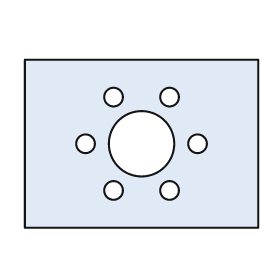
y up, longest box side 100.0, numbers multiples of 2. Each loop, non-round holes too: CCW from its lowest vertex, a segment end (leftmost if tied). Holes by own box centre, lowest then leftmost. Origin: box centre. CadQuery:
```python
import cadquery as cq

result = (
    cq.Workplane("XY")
    .moveTo(-50.0, -36.0)
    .lineTo(50.0, -36.0)
    .lineTo(50.0, 36.0)
    .lineTo(-50.0, 36.0)
    .close()
    .moveTo(-12.0, -20.0)
    .circle(4.0)
    .moveTo(12.0, -20.0)
    .circle(4.0)
    .moveTo(-24.0, 0.0)
    .circle(4.0)
    .moveTo(0.0, 0.0)
    .circle(14.0)
    .moveTo(24.0, 0.0)
    .circle(4.0)
    .moveTo(-12.0, 20.0)
    .circle(4.0)
    .moveTo(12.0, 20.0)
    .circle(4.0)
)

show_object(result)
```